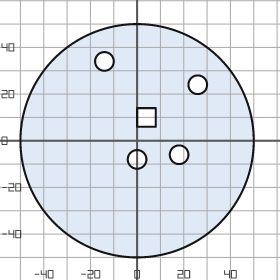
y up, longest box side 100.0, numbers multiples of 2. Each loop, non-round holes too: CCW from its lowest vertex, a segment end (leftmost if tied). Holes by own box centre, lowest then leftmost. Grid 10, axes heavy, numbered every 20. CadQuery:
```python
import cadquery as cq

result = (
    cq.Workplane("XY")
    .moveTo(0.0, 0.0)
    .circle(50.0)
    .moveTo(0.0, -8.0)
    .circle(4.0)
    .moveTo(18.0, -6.0)
    .circle(4.0)
    .moveTo(0.0, 6.0)
    .lineTo(8.0, 6.0)
    .lineTo(8.0, 14.0)
    .lineTo(0.0, 14.0)
    .close()
    .moveTo(26.0, 24.0)
    .circle(4.0)
    .moveTo(-14.0, 34.0)
    .circle(4.0)
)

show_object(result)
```